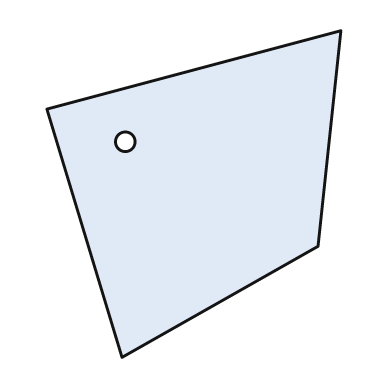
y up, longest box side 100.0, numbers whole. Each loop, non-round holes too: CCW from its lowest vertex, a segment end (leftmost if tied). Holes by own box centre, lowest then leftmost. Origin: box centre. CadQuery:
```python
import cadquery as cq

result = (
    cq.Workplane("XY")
    .moveTo(-22.0, -50.0)
    .lineTo(38.0, -16.0)
    .lineTo(45.0, 50.0)
    .lineTo(-45.0, 26.0)
    .close()
    .moveTo(-21.0, 16.0)
    .circle(3.0)
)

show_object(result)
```